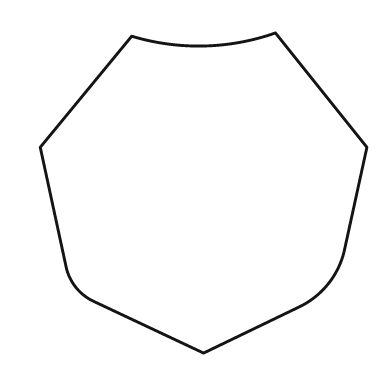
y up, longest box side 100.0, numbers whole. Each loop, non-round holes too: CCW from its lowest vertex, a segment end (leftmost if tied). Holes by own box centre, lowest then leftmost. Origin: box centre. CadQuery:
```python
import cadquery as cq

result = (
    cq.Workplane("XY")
    .moveTo(0.0, -49.0)
    .lineTo(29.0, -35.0)
    .threePointArc((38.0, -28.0), (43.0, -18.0))
    .lineTo(50.0, 14.0)
    .lineTo(22.0, 49.0)
    .threePointArc((0.0, 45.0), (-22.0, 48.0))
    .lineTo(-50.0, 14.0)
    .lineTo(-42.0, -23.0)
    .threePointArc((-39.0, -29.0), (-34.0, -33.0))
    .close()
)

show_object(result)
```